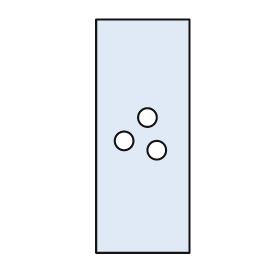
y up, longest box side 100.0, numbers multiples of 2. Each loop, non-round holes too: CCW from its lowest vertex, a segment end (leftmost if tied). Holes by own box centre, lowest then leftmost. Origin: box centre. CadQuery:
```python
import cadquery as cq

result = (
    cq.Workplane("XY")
    .moveTo(-20.0, -50.0)
    .lineTo(20.0, -50.0)
    .lineTo(20.0, 50.0)
    .lineTo(-20.0, 50.0)
    .close()
    .moveTo(6.0, -6.0)
    .circle(4.0)
    .moveTo(-8.0, -2.0)
    .circle(4.0)
    .moveTo(2.0, 8.0)
    .circle(4.0)
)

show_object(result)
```